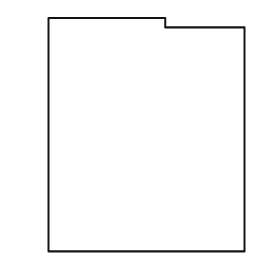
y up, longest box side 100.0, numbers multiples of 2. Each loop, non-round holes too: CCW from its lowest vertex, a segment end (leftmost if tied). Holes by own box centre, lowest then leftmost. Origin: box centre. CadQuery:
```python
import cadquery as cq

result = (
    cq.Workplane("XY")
    .moveTo(-42.0, -50.0)
    .lineTo(42.0, -50.0)
    .lineTo(42.0, 46.0)
    .lineTo(8.0, 46.0)
    .lineTo(8.0, 50.0)
    .lineTo(-42.0, 50.0)
    .close()
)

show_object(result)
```